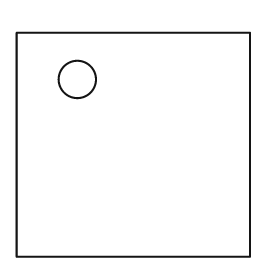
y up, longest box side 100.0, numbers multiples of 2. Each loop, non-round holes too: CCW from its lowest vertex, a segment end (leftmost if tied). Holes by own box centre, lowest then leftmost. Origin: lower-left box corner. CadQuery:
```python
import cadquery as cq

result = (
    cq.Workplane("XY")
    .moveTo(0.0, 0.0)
    .lineTo(100.0, 0.0)
    .lineTo(100.0, 96.0)
    .lineTo(0.0, 96.0)
    .close()
    .moveTo(26.0, 76.0)
    .circle(8.0)
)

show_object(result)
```